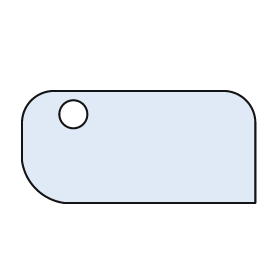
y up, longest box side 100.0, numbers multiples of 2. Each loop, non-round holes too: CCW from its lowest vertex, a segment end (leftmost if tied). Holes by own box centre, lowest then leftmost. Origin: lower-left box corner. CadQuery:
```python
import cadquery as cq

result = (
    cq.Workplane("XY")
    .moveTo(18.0, 0.0)
    .lineTo(100.0, 0.0)
    .lineTo(100.0, 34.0)
    .threePointArc((96.0, 44.0), (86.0, 48.0))
    .lineTo(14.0, 48.0)
    .threePointArc((4.0, 44.0), (0.0, 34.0))
    .lineTo(0.0, 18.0)
    .threePointArc((6.0, 6.0), (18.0, 0.0))
    .close()
    .moveTo(22.0, 38.0)
    .circle(6.0)
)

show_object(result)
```